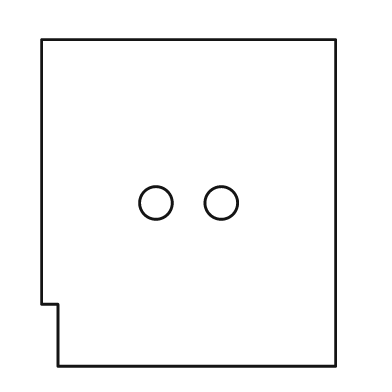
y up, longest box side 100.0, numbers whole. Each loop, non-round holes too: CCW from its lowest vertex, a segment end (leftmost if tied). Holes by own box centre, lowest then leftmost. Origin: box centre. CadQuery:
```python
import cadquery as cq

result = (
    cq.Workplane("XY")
    .moveTo(-40.0, -50.0)
    .lineTo(45.0, -50.0)
    .lineTo(45.0, 50.0)
    .lineTo(-45.0, 50.0)
    .lineTo(-45.0, -31.0)
    .lineTo(-40.0, -31.0)
    .close()
    .moveTo(-10.0, 0.0)
    .circle(5.0)
    .moveTo(10.0, 0.0)
    .circle(5.0)
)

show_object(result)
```